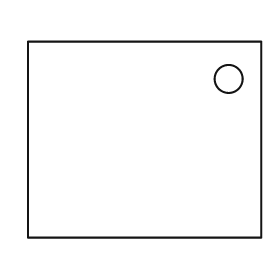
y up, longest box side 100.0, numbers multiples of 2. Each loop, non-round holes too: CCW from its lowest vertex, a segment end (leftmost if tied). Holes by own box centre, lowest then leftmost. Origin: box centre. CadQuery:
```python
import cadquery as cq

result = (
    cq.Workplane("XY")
    .moveTo(-50.0, -42.0)
    .lineTo(50.0, -42.0)
    .lineTo(50.0, 42.0)
    .lineTo(-50.0, 42.0)
    .close()
    .moveTo(36.0, 26.0)
    .circle(6.0)
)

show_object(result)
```